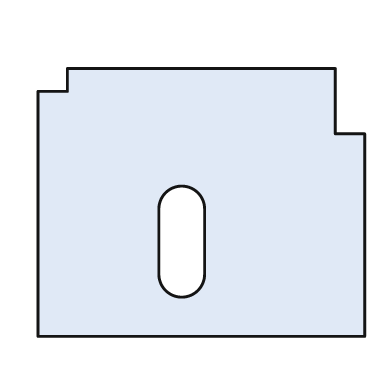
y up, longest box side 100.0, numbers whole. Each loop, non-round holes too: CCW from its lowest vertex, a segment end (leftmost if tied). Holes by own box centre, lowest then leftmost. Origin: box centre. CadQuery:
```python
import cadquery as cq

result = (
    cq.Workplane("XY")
    .moveTo(-50.0, -41.0)
    .lineTo(50.0, -41.0)
    .lineTo(50.0, 21.0)
    .lineTo(41.0, 21.0)
    .lineTo(41.0, 41.0)
    .lineTo(-41.0, 41.0)
    .lineTo(-41.0, 34.0)
    .lineTo(-50.0, 34.0)
    .close()
    .moveTo(-13.0, -22.0)
    .threePointArc((-6.0, -29.0), (1.0, -22.0))
    .lineTo(1.0, -2.0)
    .threePointArc((-6.0, 5.0), (-13.0, -2.0))
    .close()
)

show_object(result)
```